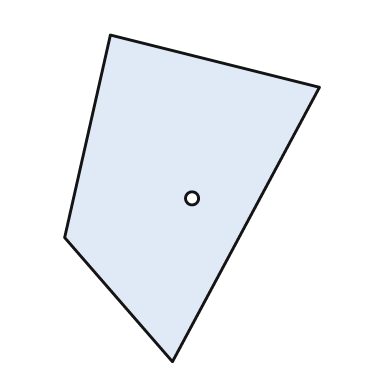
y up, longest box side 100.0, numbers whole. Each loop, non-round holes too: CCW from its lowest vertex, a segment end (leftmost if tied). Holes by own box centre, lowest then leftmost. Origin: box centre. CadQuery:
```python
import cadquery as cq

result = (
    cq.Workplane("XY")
    .moveTo(-6.0, -50.0)
    .lineTo(39.0, 34.0)
    .lineTo(-25.0, 50.0)
    .lineTo(-39.0, -12.0)
    .close()
    .moveTo(0.0, 0.0)
    .circle(2.0)
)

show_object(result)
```